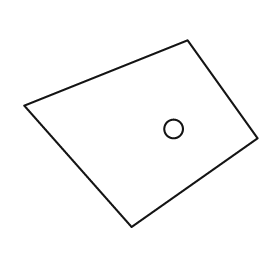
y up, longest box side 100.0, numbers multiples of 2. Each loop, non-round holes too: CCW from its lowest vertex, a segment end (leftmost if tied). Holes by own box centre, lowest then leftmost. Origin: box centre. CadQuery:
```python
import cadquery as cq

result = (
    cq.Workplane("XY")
    .moveTo(-4.0, -40.0)
    .lineTo(50.0, -2.0)
    .lineTo(20.0, 40.0)
    .lineTo(-50.0, 12.0)
    .close()
    .moveTo(14.0, 2.0)
    .circle(4.0)
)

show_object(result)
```